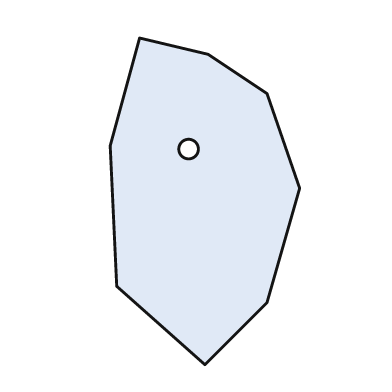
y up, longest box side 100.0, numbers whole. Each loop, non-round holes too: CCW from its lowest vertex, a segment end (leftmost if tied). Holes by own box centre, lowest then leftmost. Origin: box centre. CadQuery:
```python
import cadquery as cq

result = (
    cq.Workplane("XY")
    .moveTo(0.0, -50.0)
    .lineTo(19.0, -31.0)
    .lineTo(29.0, 4.0)
    .lineTo(19.0, 33.0)
    .lineTo(1.0, 45.0)
    .lineTo(-20.0, 50.0)
    .lineTo(-29.0, 17.0)
    .lineTo(-27.0, -26.0)
    .close()
    .moveTo(-5.0, 16.0)
    .circle(3.0)
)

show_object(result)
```